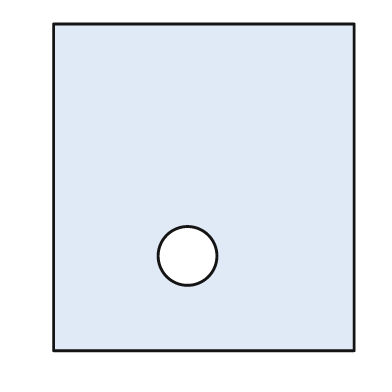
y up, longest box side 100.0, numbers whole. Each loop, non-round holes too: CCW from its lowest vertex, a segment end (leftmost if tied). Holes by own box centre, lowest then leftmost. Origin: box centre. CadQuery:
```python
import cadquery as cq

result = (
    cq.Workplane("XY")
    .moveTo(-46.0, -50.0)
    .lineTo(46.0, -50.0)
    .lineTo(46.0, 50.0)
    .lineTo(-46.0, 50.0)
    .close()
    .moveTo(-5.0, -21.0)
    .circle(9.0)
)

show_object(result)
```